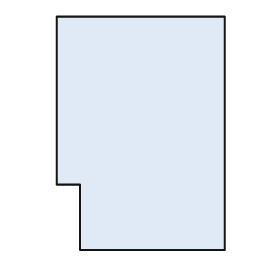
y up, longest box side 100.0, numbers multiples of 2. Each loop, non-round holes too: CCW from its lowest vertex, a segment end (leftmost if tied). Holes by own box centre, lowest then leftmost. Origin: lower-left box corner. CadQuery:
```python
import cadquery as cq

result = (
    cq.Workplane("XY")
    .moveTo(10.0, 0.0)
    .lineTo(72.0, 0.0)
    .lineTo(72.0, 100.0)
    .lineTo(0.0, 100.0)
    .lineTo(0.0, 28.0)
    .lineTo(10.0, 28.0)
    .close()
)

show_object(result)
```